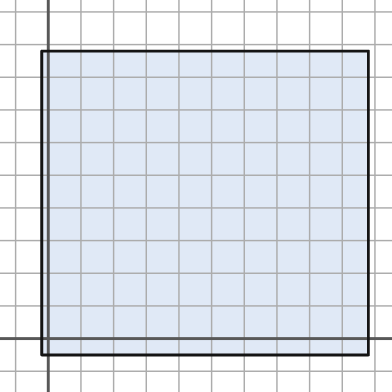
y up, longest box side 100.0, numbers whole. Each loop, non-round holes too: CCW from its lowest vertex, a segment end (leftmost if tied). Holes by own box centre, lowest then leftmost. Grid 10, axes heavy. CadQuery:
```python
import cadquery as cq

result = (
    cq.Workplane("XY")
    .moveTo(-2.0, -5.0)
    .lineTo(98.0, -5.0)
    .lineTo(98.0, 88.0)
    .lineTo(-2.0, 88.0)
    .close()
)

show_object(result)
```